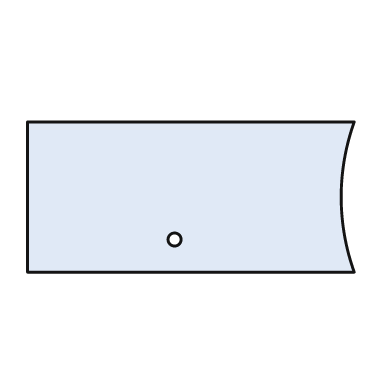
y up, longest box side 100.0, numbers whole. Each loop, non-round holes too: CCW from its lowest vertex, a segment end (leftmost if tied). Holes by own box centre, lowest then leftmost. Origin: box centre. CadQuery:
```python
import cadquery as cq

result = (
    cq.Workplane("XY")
    .moveTo(-50.0, -23.0)
    .lineTo(50.0, -23.0)
    .threePointArc((46.0, 0.0), (50.0, 23.0))
    .lineTo(-50.0, 23.0)
    .close()
    .moveTo(-5.0, -13.0)
    .circle(2.0)
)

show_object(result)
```